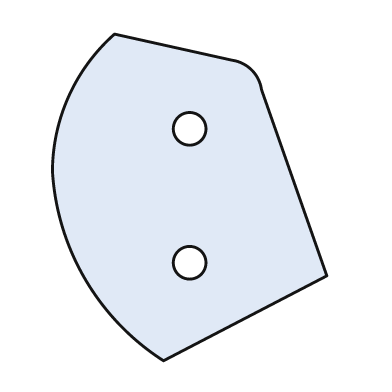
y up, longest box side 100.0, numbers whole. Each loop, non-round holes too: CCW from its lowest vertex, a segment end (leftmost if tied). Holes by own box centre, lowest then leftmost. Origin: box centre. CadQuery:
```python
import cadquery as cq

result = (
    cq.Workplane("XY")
    .moveTo(-8.0, -50.0)
    .lineTo(42.0, -24.0)
    .lineTo(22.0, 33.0)
    .threePointArc((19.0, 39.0), (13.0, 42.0))
    .lineTo(-23.0, 50.0)
    .threePointArc((-37.0, 31.0), (-42.0, 8.0))
    .threePointArc((-32.0, -25.0), (-8.0, -50.0))
    .close()
    .moveTo(0.0, -20.0)
    .circle(5.0)
    .moveTo(0.0, 21.0)
    .circle(5.0)
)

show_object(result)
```